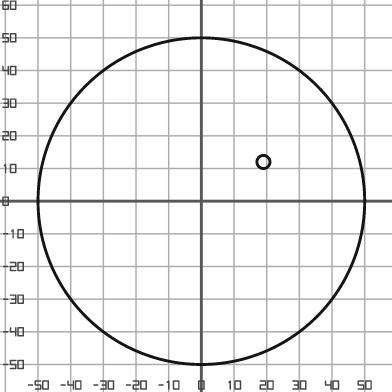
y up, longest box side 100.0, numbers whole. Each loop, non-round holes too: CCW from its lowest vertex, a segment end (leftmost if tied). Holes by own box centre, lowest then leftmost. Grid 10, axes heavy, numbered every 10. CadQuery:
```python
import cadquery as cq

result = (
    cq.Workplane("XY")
    .moveTo(0.0, 0.0)
    .circle(50.0)
    .moveTo(19.0, 12.0)
    .circle(2.0)
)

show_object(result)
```